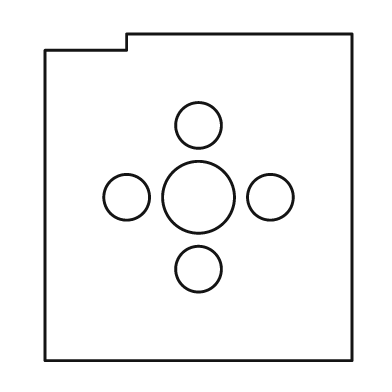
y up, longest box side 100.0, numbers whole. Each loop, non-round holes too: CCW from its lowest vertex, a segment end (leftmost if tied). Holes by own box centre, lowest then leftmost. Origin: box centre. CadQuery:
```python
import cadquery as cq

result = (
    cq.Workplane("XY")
    .moveTo(-47.0, -50.0)
    .lineTo(47.0, -50.0)
    .lineTo(47.0, 50.0)
    .lineTo(-22.0, 50.0)
    .lineTo(-22.0, 45.0)
    .lineTo(-47.0, 45.0)
    .close()
    .moveTo(0.0, -22.0)
    .circle(7.0)
    .moveTo(-22.0, 0.0)
    .circle(7.0)
    .moveTo(0.0, 0.0)
    .circle(11.0)
    .moveTo(22.0, 0.0)
    .circle(7.0)
    .moveTo(0.0, 22.0)
    .circle(7.0)
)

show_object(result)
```